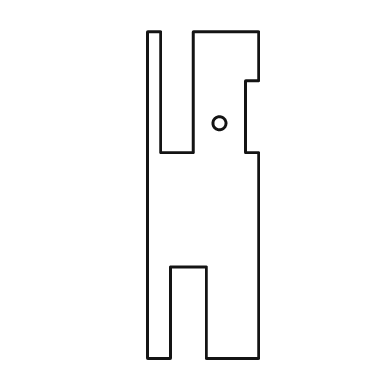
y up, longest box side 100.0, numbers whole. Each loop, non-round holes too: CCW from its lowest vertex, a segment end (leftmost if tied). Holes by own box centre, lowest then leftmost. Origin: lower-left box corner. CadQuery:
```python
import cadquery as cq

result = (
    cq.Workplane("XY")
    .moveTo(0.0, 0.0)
    .lineTo(7.0, 0.0)
    .lineTo(7.0, 28.0)
    .lineTo(18.0, 28.0)
    .lineTo(18.0, 0.0)
    .lineTo(34.0, 0.0)
    .lineTo(34.0, 63.0)
    .lineTo(30.0, 63.0)
    .lineTo(30.0, 85.0)
    .lineTo(34.0, 85.0)
    .lineTo(34.0, 100.0)
    .lineTo(14.0, 100.0)
    .lineTo(14.0, 63.0)
    .lineTo(4.0, 63.0)
    .lineTo(4.0, 100.0)
    .lineTo(0.0, 100.0)
    .close()
    .moveTo(22.0, 72.0)
    .circle(2.0)
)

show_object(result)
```